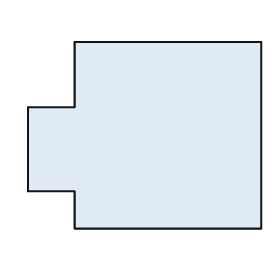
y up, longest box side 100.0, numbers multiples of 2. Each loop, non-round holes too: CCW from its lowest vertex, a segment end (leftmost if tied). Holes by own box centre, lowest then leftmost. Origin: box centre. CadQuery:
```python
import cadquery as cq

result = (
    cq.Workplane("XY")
    .moveTo(-30.0, -40.0)
    .lineTo(50.0, -40.0)
    .lineTo(50.0, 40.0)
    .lineTo(-30.0, 40.0)
    .lineTo(-30.0, 12.0)
    .lineTo(-50.0, 12.0)
    .lineTo(-50.0, -24.0)
    .lineTo(-30.0, -24.0)
    .close()
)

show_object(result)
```